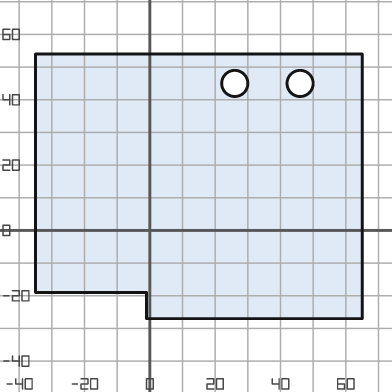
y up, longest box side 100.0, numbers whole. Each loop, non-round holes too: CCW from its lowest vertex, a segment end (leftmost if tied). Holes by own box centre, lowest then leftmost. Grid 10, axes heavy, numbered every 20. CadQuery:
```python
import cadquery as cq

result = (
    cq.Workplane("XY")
    .moveTo(-1.0, -27.0)
    .lineTo(65.0, -27.0)
    .lineTo(65.0, 54.0)
    .lineTo(-35.0, 54.0)
    .lineTo(-35.0, -19.0)
    .lineTo(-1.0, -19.0)
    .close()
    .moveTo(26.0, 45.0)
    .circle(4.0)
    .moveTo(46.0, 45.0)
    .circle(4.0)
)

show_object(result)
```